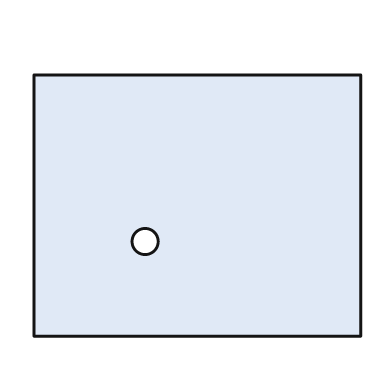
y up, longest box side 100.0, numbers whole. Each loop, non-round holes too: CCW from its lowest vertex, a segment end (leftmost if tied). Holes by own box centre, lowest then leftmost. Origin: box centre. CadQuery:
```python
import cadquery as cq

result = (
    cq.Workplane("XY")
    .moveTo(-50.0, -40.0)
    .lineTo(50.0, -40.0)
    .lineTo(50.0, 40.0)
    .lineTo(-50.0, 40.0)
    .close()
    .moveTo(-16.0, -11.0)
    .circle(4.0)
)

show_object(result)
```